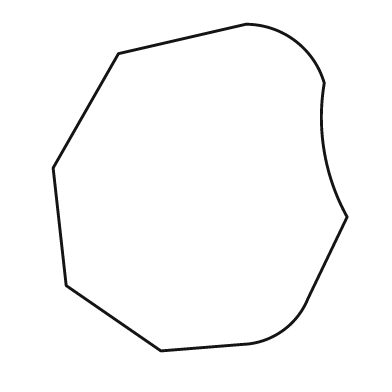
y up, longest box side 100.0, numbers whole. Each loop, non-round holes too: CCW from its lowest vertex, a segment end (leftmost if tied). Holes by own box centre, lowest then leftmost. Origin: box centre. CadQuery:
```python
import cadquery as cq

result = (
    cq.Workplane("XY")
    .moveTo(-12.0, -50.0)
    .lineTo(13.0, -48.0)
    .threePointArc((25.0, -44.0), (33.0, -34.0))
    .lineTo(45.0, -9.0)
    .threePointArc((38.0, 11.0), (38.0, 32.0))
    .threePointArc((29.0, 45.0), (14.0, 50.0))
    .lineTo(-25.0, 41.0)
    .lineTo(-45.0, 6.0)
    .lineTo(-41.0, -30.0)
    .close()
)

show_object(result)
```